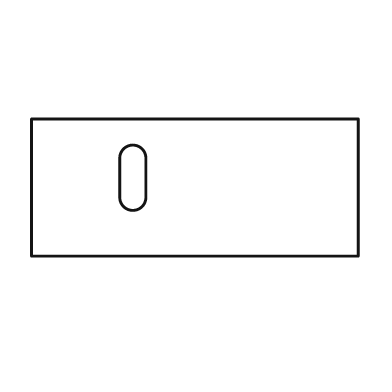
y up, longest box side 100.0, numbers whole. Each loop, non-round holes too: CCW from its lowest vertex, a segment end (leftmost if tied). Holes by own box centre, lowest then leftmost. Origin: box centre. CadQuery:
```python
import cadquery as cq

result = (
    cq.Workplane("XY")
    .moveTo(-50.0, -21.0)
    .lineTo(50.0, -21.0)
    .lineTo(50.0, 21.0)
    .lineTo(-50.0, 21.0)
    .close()
    .moveTo(-23.0, -3.0)
    .threePointArc((-19.0, -7.0), (-15.0, -3.0))
    .lineTo(-15.0, 9.0)
    .threePointArc((-19.0, 13.0), (-23.0, 9.0))
    .close()
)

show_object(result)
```